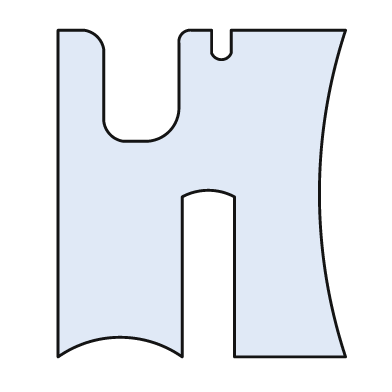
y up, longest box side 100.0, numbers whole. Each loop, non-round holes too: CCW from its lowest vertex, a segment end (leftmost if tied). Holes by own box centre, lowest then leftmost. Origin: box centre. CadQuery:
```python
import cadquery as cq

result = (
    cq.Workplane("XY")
    .moveTo(-44.0, -50.0)
    .threePointArc((-25.0, -44.0), (-6.0, -50.0))
    .lineTo(-6.0, -1.0)
    .threePointArc((2.0, 1.0), (10.0, -1.0))
    .lineTo(10.0, -50.0)
    .lineTo(44.0, -50.0)
    .threePointArc((36.0, 0.0), (44.0, 50.0))
    .lineTo(9.0, 50.0)
    .lineTo(9.0, 43.0)
    .threePointArc((6.0, 41.0), (3.0, 43.0))
    .lineTo(3.0, 50.0)
    .lineTo(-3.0, 50.0)
    .threePointArc((-6.0, 49.0), (-7.0, 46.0))
    .lineTo(-7.0, 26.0)
    .threePointArc((-10.0, 19.0), (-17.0, 16.0))
    .lineTo(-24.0, 16.0)
    .threePointArc((-28.0, 18.0), (-30.0, 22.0))
    .lineTo(-30.0, 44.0)
    .threePointArc((-32.0, 48.0), (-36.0, 50.0))
    .lineTo(-44.0, 50.0)
    .close()
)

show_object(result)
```